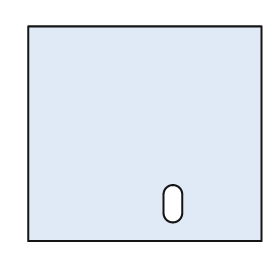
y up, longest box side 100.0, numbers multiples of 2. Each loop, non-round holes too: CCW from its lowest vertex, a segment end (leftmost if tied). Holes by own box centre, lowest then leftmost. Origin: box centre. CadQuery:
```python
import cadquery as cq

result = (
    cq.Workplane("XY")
    .moveTo(-50.0, -46.0)
    .lineTo(50.0, -46.0)
    .lineTo(50.0, 46.0)
    .lineTo(-50.0, 46.0)
    .close()
    .moveTo(8.0, -34.0)
    .threePointArc((12.0, -38.0), (16.0, -34.0))
    .lineTo(16.0, -26.0)
    .threePointArc((12.0, -22.0), (8.0, -26.0))
    .close()
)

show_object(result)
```